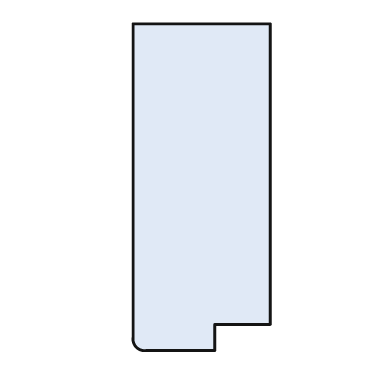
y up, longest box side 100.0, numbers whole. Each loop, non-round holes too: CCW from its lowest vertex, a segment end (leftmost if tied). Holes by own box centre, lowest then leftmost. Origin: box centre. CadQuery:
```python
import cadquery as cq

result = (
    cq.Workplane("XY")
    .moveTo(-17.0, -50.0)
    .lineTo(4.0, -50.0)
    .lineTo(4.0, -42.0)
    .lineTo(21.0, -42.0)
    .lineTo(21.0, 50.0)
    .lineTo(-21.0, 50.0)
    .lineTo(-21.0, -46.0)
    .threePointArc((-20.0, -49.0), (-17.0, -50.0))
    .close()
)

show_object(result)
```